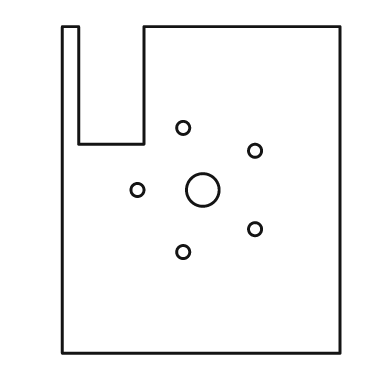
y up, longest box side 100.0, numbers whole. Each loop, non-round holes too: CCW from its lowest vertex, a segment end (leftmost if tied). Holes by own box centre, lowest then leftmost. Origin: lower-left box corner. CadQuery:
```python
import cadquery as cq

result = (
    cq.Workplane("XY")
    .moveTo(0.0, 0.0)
    .lineTo(85.0, 0.0)
    .lineTo(85.0, 100.0)
    .lineTo(25.0, 100.0)
    .lineTo(25.0, 64.0)
    .lineTo(5.0, 64.0)
    .lineTo(5.0, 100.0)
    .lineTo(0.0, 100.0)
    .close()
    .moveTo(37.0, 31.0)
    .circle(2.0)
    .moveTo(59.0, 38.0)
    .circle(2.0)
    .moveTo(23.0, 50.0)
    .circle(2.0)
    .moveTo(43.0, 50.0)
    .circle(5.0)
    .moveTo(59.0, 62.0)
    .circle(2.0)
    .moveTo(37.0, 69.0)
    .circle(2.0)
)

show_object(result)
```